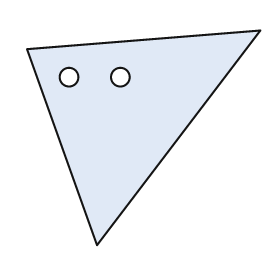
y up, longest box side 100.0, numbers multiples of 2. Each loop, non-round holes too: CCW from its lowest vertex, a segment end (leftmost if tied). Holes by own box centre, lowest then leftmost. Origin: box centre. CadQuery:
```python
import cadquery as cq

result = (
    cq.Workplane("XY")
    .moveTo(-20.0, -46.0)
    .lineTo(50.0, 46.0)
    .lineTo(-50.0, 38.0)
    .close()
    .moveTo(-32.0, 26.0)
    .circle(4.0)
    .moveTo(-10.0, 26.0)
    .circle(4.0)
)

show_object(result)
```